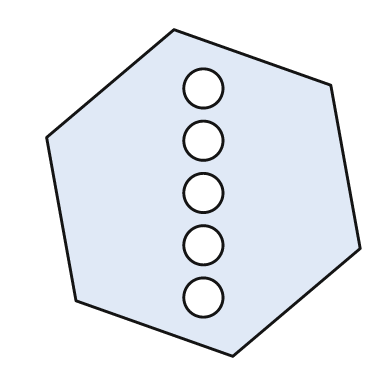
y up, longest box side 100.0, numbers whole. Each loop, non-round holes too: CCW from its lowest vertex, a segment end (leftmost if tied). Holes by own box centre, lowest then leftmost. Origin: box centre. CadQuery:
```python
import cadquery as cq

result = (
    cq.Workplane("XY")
    .moveTo(9.0, -50.0)
    .lineTo(48.0, -17.0)
    .lineTo(39.0, 33.0)
    .lineTo(-9.0, 50.0)
    .lineTo(-48.0, 17.0)
    .lineTo(-39.0, -33.0)
    .close()
    .moveTo(0.0, -32.0)
    .circle(6.0)
    .moveTo(0.0, -16.0)
    .circle(6.0)
    .moveTo(0.0, 0.0)
    .circle(6.0)
    .moveTo(0.0, 16.0)
    .circle(6.0)
    .moveTo(0.0, 32.0)
    .circle(6.0)
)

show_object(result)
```